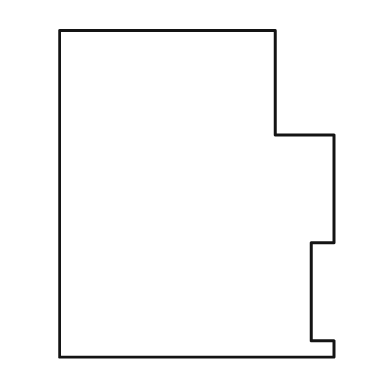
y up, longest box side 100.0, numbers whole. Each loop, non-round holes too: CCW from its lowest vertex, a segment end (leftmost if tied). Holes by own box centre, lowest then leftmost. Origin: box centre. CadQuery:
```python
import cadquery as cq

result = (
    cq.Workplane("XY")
    .moveTo(-42.0, -50.0)
    .lineTo(42.0, -50.0)
    .lineTo(42.0, -45.0)
    .lineTo(35.0, -45.0)
    .lineTo(35.0, -15.0)
    .lineTo(42.0, -15.0)
    .lineTo(42.0, 18.0)
    .lineTo(24.0, 18.0)
    .lineTo(24.0, 50.0)
    .lineTo(-42.0, 50.0)
    .close()
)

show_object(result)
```